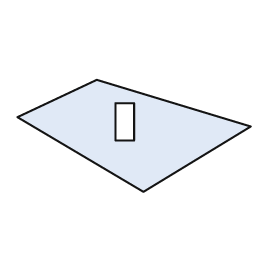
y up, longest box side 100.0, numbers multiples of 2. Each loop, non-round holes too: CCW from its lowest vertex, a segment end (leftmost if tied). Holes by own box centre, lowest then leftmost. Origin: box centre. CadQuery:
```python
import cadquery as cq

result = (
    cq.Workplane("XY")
    .moveTo(4.0, -24.0)
    .lineTo(50.0, 4.0)
    .lineTo(-16.0, 24.0)
    .lineTo(-50.0, 8.0)
    .close()
    .moveTo(-8.0, -2.0)
    .lineTo(0.0, -2.0)
    .lineTo(0.0, 14.0)
    .lineTo(-8.0, 14.0)
    .close()
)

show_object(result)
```